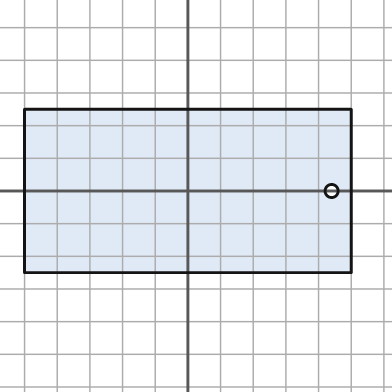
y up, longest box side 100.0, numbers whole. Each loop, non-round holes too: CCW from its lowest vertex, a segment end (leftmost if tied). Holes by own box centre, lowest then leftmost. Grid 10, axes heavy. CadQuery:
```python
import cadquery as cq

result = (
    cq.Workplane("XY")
    .moveTo(-50.0, -25.0)
    .lineTo(50.0, -25.0)
    .lineTo(50.0, 25.0)
    .lineTo(-50.0, 25.0)
    .close()
    .moveTo(44.0, 0.0)
    .circle(2.0)
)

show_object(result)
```